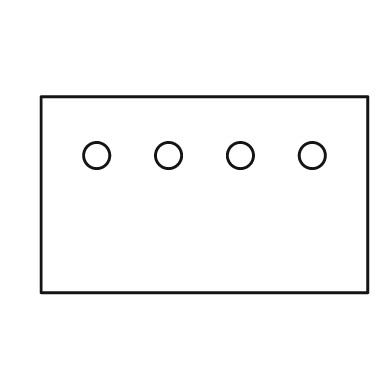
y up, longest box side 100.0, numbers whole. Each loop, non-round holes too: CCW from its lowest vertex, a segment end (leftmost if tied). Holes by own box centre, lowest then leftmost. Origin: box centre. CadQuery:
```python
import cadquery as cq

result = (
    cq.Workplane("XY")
    .moveTo(-50.0, -30.0)
    .lineTo(50.0, -30.0)
    .lineTo(50.0, 30.0)
    .lineTo(-50.0, 30.0)
    .close()
    .moveTo(-33.0, 12.0)
    .circle(4.0)
    .moveTo(-11.0, 12.0)
    .circle(4.0)
    .moveTo(11.0, 12.0)
    .circle(4.0)
    .moveTo(33.0, 12.0)
    .circle(4.0)
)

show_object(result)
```